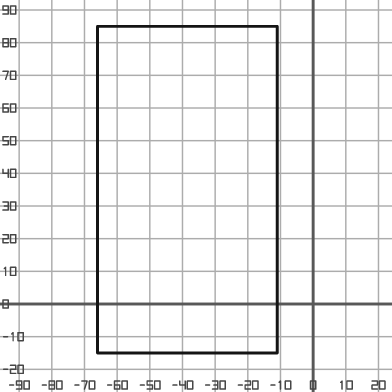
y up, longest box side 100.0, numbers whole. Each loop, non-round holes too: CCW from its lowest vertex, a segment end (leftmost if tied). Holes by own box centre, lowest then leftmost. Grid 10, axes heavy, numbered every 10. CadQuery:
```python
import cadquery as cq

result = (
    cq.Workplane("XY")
    .moveTo(-66.0, -15.0)
    .lineTo(-11.0, -15.0)
    .lineTo(-11.0, 85.0)
    .lineTo(-66.0, 85.0)
    .close()
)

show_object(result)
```